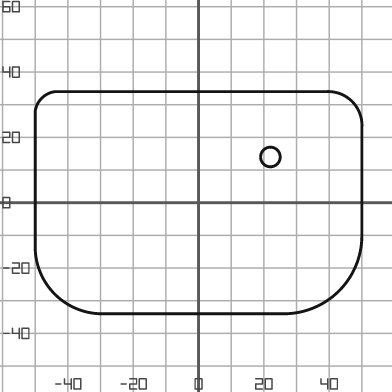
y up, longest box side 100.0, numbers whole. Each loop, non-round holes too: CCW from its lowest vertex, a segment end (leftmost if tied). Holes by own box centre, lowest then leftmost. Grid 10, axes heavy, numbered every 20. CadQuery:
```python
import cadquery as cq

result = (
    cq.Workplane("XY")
    .moveTo(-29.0, -34.0)
    .lineTo(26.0, -34.0)
    .threePointArc((43.0, -27.0), (50.0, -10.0))
    .lineTo(50.0, 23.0)
    .threePointArc((47.0, 31.0), (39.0, 34.0))
    .lineTo(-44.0, 34.0)
    .threePointArc((-48.0, 32.0), (-50.0, 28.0))
    .lineTo(-50.0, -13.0)
    .threePointArc((-44.0, -28.0), (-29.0, -34.0))
    .close()
    .moveTo(22.0, 14.0)
    .circle(3.0)
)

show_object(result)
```